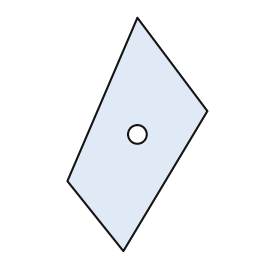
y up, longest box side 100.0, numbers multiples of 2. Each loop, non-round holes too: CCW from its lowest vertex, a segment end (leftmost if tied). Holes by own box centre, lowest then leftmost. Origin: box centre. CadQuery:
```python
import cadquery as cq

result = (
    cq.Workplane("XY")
    .moveTo(-6.0, -50.0)
    .lineTo(30.0, 10.0)
    .lineTo(0.0, 50.0)
    .lineTo(-30.0, -20.0)
    .close()
    .moveTo(0.0, 0.0)
    .circle(4.0)
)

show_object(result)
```